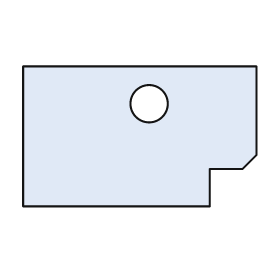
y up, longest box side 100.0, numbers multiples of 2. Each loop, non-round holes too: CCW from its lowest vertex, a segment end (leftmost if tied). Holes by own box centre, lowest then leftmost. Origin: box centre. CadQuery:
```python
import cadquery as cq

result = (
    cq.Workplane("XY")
    .moveTo(-50.0, -30.0)
    .lineTo(30.0, -30.0)
    .lineTo(30.0, -14.0)
    .lineTo(44.0, -14.0)
    .lineTo(50.0, -8.0)
    .lineTo(50.0, 30.0)
    .lineTo(-50.0, 30.0)
    .close()
    .moveTo(4.0, 14.0)
    .circle(8.0)
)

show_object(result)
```